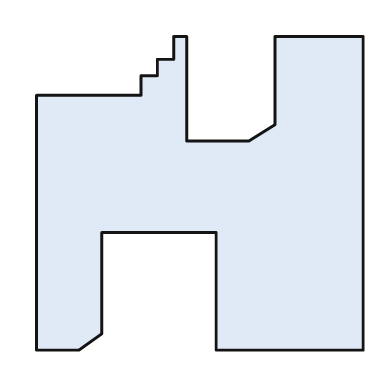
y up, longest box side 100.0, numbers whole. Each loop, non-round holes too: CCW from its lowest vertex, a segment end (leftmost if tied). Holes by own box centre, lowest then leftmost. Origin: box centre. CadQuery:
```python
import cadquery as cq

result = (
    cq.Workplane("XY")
    .moveTo(-50.0, -48.0)
    .lineTo(-37.0, -48.0)
    .lineTo(-30.0, -43.0)
    .lineTo(-30.0, -12.0)
    .lineTo(5.0, -12.0)
    .lineTo(5.0, -48.0)
    .lineTo(50.0, -48.0)
    .lineTo(50.0, 48.0)
    .lineTo(23.0, 48.0)
    .lineTo(23.0, 21.0)
    .lineTo(15.0, 16.0)
    .lineTo(-4.0, 16.0)
    .lineTo(-4.0, 48.0)
    .lineTo(-8.0, 48.0)
    .lineTo(-8.0, 41.0)
    .lineTo(-13.0, 41.0)
    .lineTo(-13.0, 36.0)
    .lineTo(-18.0, 36.0)
    .lineTo(-18.0, 30.0)
    .lineTo(-50.0, 30.0)
    .close()
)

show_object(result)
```